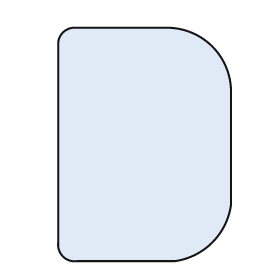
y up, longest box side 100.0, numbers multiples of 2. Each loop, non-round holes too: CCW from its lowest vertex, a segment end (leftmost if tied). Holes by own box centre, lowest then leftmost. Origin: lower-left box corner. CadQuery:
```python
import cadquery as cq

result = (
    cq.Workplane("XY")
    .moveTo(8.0, 0.0)
    .lineTo(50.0, 0.0)
    .threePointArc((66.0, 8.0), (74.0, 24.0))
    .lineTo(74.0, 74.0)
    .threePointArc((66.0, 92.0), (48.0, 100.0))
    .lineTo(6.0, 100.0)
    .threePointArc((2.0, 98.0), (0.0, 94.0))
    .lineTo(0.0, 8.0)
    .threePointArc((2.0, 2.0), (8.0, 0.0))
    .close()
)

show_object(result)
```